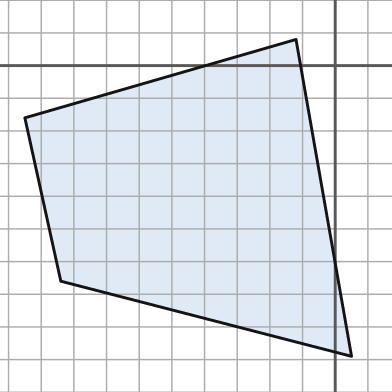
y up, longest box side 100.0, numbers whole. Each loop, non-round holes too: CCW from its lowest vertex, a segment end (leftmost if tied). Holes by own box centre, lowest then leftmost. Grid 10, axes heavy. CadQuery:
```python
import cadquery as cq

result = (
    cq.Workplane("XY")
    .moveTo(5.0, -89.0)
    .lineTo(-12.0, 8.0)
    .lineTo(-95.0, -16.0)
    .lineTo(-84.0, -66.0)
    .close()
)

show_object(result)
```